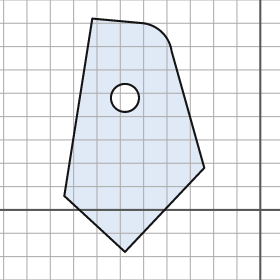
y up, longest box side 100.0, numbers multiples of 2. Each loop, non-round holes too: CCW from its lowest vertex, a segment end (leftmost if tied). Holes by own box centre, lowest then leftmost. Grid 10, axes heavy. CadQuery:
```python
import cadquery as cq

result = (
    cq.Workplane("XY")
    .moveTo(-58.0, -18.0)
    .lineTo(-24.0, 18.0)
    .lineTo(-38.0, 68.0)
    .threePointArc((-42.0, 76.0), (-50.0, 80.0))
    .lineTo(-72.0, 82.0)
    .lineTo(-84.0, 6.0)
    .close()
    .moveTo(-58.0, 48.0)
    .circle(6.0)
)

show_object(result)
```